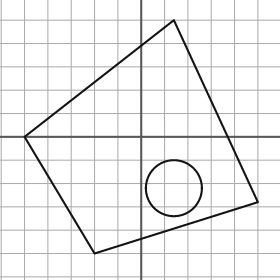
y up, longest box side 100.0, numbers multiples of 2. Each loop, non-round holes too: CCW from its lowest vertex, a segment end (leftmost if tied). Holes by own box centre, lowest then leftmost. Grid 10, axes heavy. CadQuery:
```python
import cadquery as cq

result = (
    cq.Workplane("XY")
    .moveTo(-20.0, -50.0)
    .lineTo(50.0, -28.0)
    .lineTo(14.0, 50.0)
    .lineTo(-50.0, 0.0)
    .close()
    .moveTo(14.0, -22.0)
    .circle(12.0)
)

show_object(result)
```